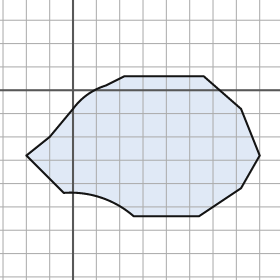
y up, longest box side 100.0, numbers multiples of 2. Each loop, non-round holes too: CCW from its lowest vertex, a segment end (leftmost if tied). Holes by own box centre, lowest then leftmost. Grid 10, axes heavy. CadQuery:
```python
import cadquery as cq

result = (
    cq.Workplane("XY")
    .moveTo(26.0, -54.0)
    .lineTo(54.0, -54.0)
    .lineTo(72.0, -42.0)
    .lineTo(80.0, -28.0)
    .lineTo(72.0, -8.0)
    .lineTo(56.0, 6.0)
    .lineTo(22.0, 6.0)
    .lineTo(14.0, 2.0)
    .threePointArc((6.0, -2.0), (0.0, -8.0))
    .lineTo(-10.0, -20.0)
    .lineTo(-20.0, -28.0)
    .lineTo(-4.0, -44.0)
    .threePointArc((12.0, -46.0), (26.0, -54.0))
    .close()
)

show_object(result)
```